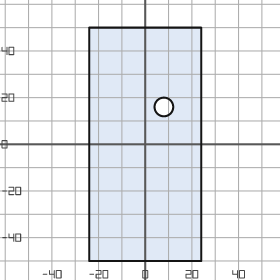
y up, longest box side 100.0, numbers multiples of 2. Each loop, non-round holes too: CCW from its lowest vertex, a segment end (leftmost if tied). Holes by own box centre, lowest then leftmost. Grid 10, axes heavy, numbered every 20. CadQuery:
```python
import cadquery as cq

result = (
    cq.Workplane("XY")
    .moveTo(-24.0, -50.0)
    .lineTo(24.0, -50.0)
    .lineTo(24.0, 50.0)
    .lineTo(-24.0, 50.0)
    .close()
    .moveTo(8.0, 16.0)
    .circle(4.0)
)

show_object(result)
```